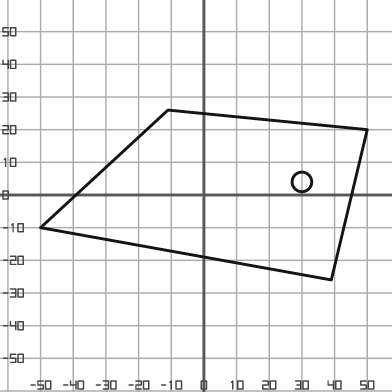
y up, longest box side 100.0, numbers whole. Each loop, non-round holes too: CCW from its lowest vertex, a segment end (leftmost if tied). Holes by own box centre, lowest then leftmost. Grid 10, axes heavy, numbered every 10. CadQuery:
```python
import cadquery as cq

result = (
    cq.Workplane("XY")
    .moveTo(39.0, -26.0)
    .lineTo(50.0, 20.0)
    .lineTo(-11.0, 26.0)
    .lineTo(-50.0, -10.0)
    .close()
    .moveTo(30.0, 4.0)
    .circle(3.0)
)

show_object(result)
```